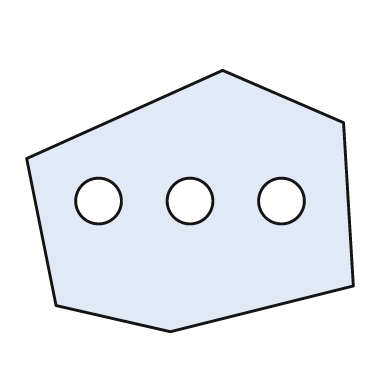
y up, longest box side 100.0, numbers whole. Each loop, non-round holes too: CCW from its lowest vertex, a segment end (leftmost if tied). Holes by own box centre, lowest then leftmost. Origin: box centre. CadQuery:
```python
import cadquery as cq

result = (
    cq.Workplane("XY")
    .moveTo(-6.0, -40.0)
    .lineTo(50.0, -26.0)
    .lineTo(47.0, 24.0)
    .lineTo(10.0, 40.0)
    .lineTo(-50.0, 13.0)
    .lineTo(-41.0, -32.0)
    .close()
    .moveTo(-28.0, 0.0)
    .circle(7.0)
    .moveTo(0.0, 0.0)
    .circle(7.0)
    .moveTo(28.0, 0.0)
    .circle(7.0)
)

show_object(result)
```